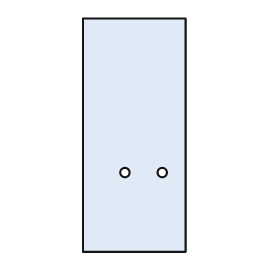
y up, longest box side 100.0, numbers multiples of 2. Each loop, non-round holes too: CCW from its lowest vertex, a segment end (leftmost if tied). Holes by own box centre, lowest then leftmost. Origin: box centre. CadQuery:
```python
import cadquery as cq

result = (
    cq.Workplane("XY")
    .moveTo(-22.0, -50.0)
    .lineTo(22.0, -50.0)
    .lineTo(22.0, 50.0)
    .lineTo(-22.0, 50.0)
    .close()
    .moveTo(-4.0, -16.0)
    .circle(2.0)
    .moveTo(12.0, -16.0)
    .circle(2.0)
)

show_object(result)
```